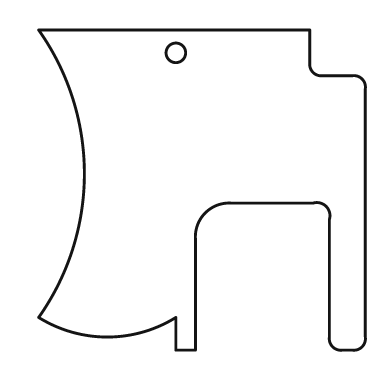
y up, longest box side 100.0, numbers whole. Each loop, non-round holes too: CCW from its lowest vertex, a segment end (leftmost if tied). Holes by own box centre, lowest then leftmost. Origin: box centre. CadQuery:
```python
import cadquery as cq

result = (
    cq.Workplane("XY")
    .moveTo(-8.0, -49.0)
    .lineTo(-2.0, -49.0)
    .lineTo(-2.0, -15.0)
    .threePointArc((1.0, -7.0), (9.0, -4.0))
    .lineTo(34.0, -4.0)
    .threePointArc((38.0, -5.0), (39.0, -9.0))
    .lineTo(39.0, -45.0)
    .threePointArc((40.0, -48.0), (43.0, -49.0))
    .lineTo(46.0, -49.0)
    .threePointArc((49.0, -48.0), (50.0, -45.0))
    .lineTo(50.0, 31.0)
    .threePointArc((49.0, 34.0), (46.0, 35.0))
    .lineTo(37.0, 35.0)
    .threePointArc((34.0, 36.0), (33.0, 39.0))
    .lineTo(33.0, 49.0)
    .lineTo(-50.0, 49.0)
    .threePointArc((-36.0, 5.0), (-50.0, -39.0))
    .threePointArc((-29.0, -45.0), (-8.0, -39.0))
    .close()
    .moveTo(-8.0, 42.0)
    .circle(3.0)
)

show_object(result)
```